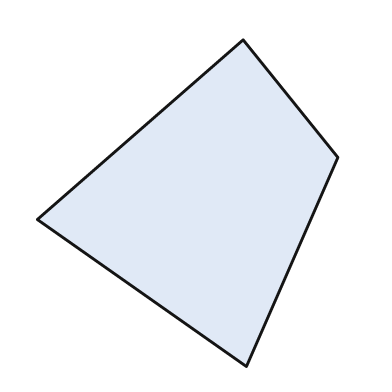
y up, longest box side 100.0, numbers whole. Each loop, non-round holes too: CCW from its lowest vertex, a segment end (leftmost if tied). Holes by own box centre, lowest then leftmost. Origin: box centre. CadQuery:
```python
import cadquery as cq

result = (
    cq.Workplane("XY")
    .moveTo(18.0, -50.0)
    .lineTo(46.0, 14.0)
    .lineTo(17.0, 50.0)
    .lineTo(-46.0, -5.0)
    .close()
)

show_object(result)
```